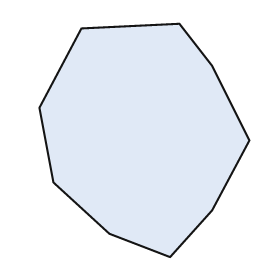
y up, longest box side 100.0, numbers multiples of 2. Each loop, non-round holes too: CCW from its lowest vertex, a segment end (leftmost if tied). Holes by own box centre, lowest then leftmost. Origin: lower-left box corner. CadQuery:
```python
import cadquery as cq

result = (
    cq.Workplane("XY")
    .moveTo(56.0, 0.0)
    .lineTo(74.0, 20.0)
    .lineTo(90.0, 50.0)
    .lineTo(74.0, 82.0)
    .lineTo(60.0, 100.0)
    .lineTo(18.0, 98.0)
    .lineTo(0.0, 64.0)
    .lineTo(6.0, 32.0)
    .lineTo(30.0, 10.0)
    .close()
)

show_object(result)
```